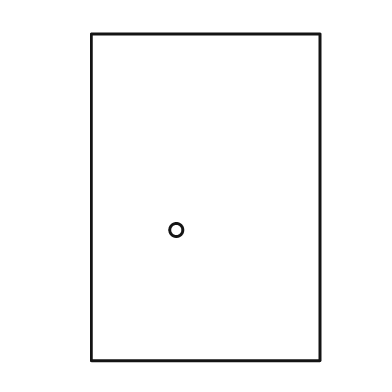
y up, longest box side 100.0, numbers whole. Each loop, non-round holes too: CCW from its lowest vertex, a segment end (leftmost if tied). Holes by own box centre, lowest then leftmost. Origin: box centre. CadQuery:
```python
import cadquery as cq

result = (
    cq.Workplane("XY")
    .moveTo(-35.0, -50.0)
    .lineTo(35.0, -50.0)
    .lineTo(35.0, 50.0)
    .lineTo(-35.0, 50.0)
    .close()
    .moveTo(-9.0, -10.0)
    .circle(2.0)
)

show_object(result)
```